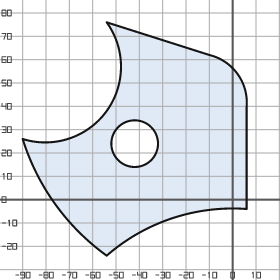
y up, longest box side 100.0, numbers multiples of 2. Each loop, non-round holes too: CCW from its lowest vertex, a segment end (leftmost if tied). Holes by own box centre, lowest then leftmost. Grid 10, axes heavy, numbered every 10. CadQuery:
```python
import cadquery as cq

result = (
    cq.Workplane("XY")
    .moveTo(-54.0, -24.0)
    .threePointArc((-26.0, -8.0), (6.0, -4.0))
    .lineTo(6.0, 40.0)
    .threePointArc((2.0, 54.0), (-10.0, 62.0))
    .lineTo(-54.0, 76.0)
    .threePointArc((-54.0, 38.0), (-90.0, 26.0))
    .threePointArc((-76.0, -2.0), (-54.0, -24.0))
    .close()
    .moveTo(-42.0, 24.0)
    .circle(10.0)
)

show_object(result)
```